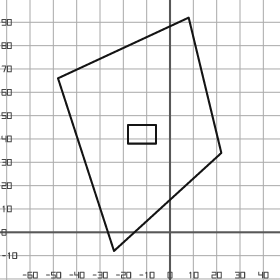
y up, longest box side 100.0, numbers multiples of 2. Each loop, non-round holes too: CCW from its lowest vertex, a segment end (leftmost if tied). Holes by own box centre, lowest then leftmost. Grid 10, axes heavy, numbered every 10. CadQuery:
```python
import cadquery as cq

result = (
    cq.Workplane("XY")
    .moveTo(-24.0, -8.0)
    .lineTo(22.0, 34.0)
    .lineTo(8.0, 92.0)
    .lineTo(-48.0, 66.0)
    .close()
    .moveTo(-18.0, 38.0)
    .lineTo(-6.0, 38.0)
    .lineTo(-6.0, 46.0)
    .lineTo(-18.0, 46.0)
    .close()
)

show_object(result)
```